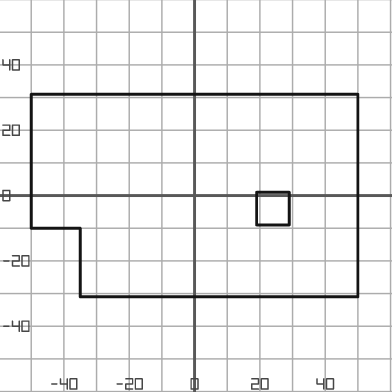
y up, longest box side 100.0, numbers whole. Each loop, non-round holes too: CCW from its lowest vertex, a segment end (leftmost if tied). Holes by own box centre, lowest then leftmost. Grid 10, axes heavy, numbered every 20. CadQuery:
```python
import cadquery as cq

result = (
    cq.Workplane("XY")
    .moveTo(-35.0, -31.0)
    .lineTo(50.0, -31.0)
    .lineTo(50.0, 31.0)
    .lineTo(-50.0, 31.0)
    .lineTo(-50.0, -10.0)
    .lineTo(-35.0, -10.0)
    .close()
    .moveTo(19.0, -9.0)
    .lineTo(29.0, -9.0)
    .lineTo(29.0, 1.0)
    .lineTo(19.0, 1.0)
    .close()
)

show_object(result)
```